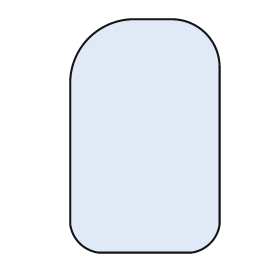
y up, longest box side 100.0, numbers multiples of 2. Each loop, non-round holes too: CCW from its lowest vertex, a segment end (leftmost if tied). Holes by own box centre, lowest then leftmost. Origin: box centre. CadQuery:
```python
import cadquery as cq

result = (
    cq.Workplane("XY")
    .moveTo(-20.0, -50.0)
    .lineTo(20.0, -50.0)
    .threePointArc((28.0, -46.0), (32.0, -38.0))
    .lineTo(32.0, 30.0)
    .threePointArc((26.0, 44.0), (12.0, 50.0))
    .lineTo(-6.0, 50.0)
    .threePointArc((-24.0, 42.0), (-32.0, 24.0))
    .lineTo(-32.0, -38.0)
    .threePointArc((-28.0, -46.0), (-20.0, -50.0))
    .close()
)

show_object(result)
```